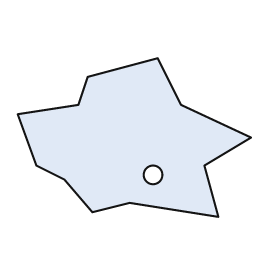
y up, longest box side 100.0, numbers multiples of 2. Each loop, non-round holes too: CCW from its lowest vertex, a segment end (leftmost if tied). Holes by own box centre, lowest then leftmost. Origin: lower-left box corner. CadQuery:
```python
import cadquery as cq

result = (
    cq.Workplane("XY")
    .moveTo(86.0, 0.0)
    .lineTo(80.0, 22.0)
    .lineTo(100.0, 34.0)
    .lineTo(70.0, 48.0)
    .lineTo(60.0, 68.0)
    .lineTo(30.0, 60.0)
    .lineTo(26.0, 48.0)
    .lineTo(0.0, 44.0)
    .lineTo(8.0, 22.0)
    .lineTo(20.0, 16.0)
    .lineTo(32.0, 2.0)
    .lineTo(48.0, 6.0)
    .close()
    .moveTo(58.0, 18.0)
    .circle(4.0)
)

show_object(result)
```